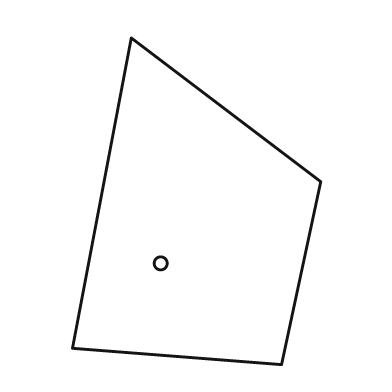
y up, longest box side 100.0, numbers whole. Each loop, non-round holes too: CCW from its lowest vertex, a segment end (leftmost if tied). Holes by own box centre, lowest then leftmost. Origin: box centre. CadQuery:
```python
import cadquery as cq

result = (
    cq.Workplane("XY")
    .moveTo(26.0, -50.0)
    .lineTo(38.0, 6.0)
    .lineTo(-20.0, 50.0)
    .lineTo(-38.0, -45.0)
    .close()
    .moveTo(-11.0, -19.0)
    .circle(2.0)
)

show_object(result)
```